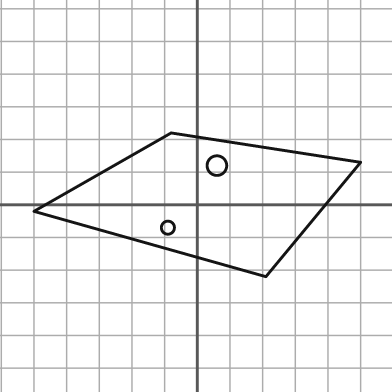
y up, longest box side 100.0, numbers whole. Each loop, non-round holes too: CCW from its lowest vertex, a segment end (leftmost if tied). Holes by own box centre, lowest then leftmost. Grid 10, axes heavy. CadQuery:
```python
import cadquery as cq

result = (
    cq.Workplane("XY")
    .moveTo(21.0, -22.0)
    .lineTo(50.0, 13.0)
    .lineTo(-8.0, 22.0)
    .lineTo(-50.0, -2.0)
    .close()
    .moveTo(-9.0, -7.0)
    .circle(2.0)
    .moveTo(6.0, 12.0)
    .circle(3.0)
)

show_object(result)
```